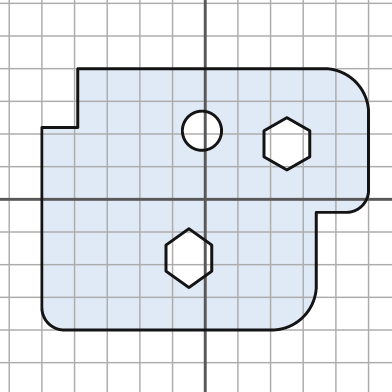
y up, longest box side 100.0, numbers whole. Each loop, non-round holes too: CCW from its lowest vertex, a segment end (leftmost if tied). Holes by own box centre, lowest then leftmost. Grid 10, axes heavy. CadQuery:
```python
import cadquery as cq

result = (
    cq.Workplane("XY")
    .moveTo(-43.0, -40.0)
    .lineTo(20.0, -40.0)
    .threePointArc((30.0, -36.0), (34.0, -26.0))
    .lineTo(34.0, -4.0)
    .lineTo(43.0, -4.0)
    .threePointArc((48.0, -2.0), (50.0, 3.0))
    .lineTo(50.0, 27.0)
    .threePointArc((46.0, 36.0), (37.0, 40.0))
    .lineTo(-39.0, 40.0)
    .lineTo(-39.0, 22.0)
    .lineTo(-50.0, 22.0)
    .lineTo(-50.0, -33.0)
    .threePointArc((-48.0, -38.0), (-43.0, -40.0))
    .close()
    .moveTo(-5.0, -27.0)
    .lineTo(2.0, -22.0)
    .lineTo(2.0, -14.0)
    .lineTo(-5.0, -9.0)
    .lineTo(-12.0, -14.0)
    .lineTo(-12.0, -22.0)
    .close()
    .moveTo(25.0, 9.0)
    .lineTo(32.0, 13.0)
    .lineTo(32.0, 21.0)
    .lineTo(25.0, 25.0)
    .lineTo(18.0, 21.0)
    .lineTo(18.0, 13.0)
    .close()
    .moveTo(-1.0, 21.0)
    .circle(6.0)
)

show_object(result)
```